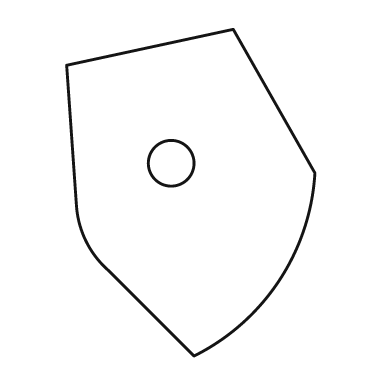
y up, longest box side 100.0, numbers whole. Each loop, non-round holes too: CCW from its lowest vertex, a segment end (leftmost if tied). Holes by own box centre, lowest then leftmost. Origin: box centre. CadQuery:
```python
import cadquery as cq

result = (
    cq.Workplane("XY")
    .moveTo(1.0, -50.0)
    .threePointArc((27.0, -27.0), (38.0, 6.0))
    .lineTo(13.0, 50.0)
    .lineTo(-38.0, 39.0)
    .lineTo(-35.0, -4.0)
    .threePointArc((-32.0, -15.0), (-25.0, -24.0))
    .close()
    .moveTo(-6.0, 9.0)
    .circle(7.0)
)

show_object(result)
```